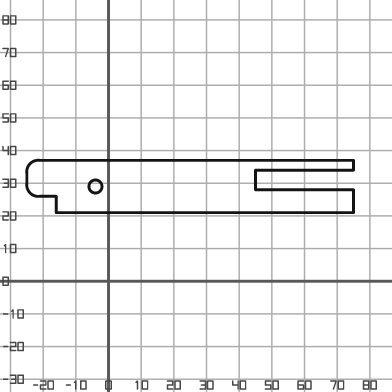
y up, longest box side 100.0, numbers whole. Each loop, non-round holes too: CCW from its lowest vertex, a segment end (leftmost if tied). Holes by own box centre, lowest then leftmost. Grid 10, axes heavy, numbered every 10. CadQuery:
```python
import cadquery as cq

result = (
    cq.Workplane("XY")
    .moveTo(-16.0, 21.0)
    .lineTo(75.0, 21.0)
    .lineTo(75.0, 28.0)
    .lineTo(45.0, 28.0)
    .lineTo(45.0, 34.0)
    .lineTo(75.0, 34.0)
    .lineTo(75.0, 37.0)
    .lineTo(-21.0, 37.0)
    .threePointArc((-24.0, 36.0), (-25.0, 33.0))
    .lineTo(-25.0, 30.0)
    .threePointArc((-24.0, 27.0), (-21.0, 26.0))
    .lineTo(-16.0, 26.0)
    .close()
    .moveTo(-4.0, 29.0)
    .circle(2.0)
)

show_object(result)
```